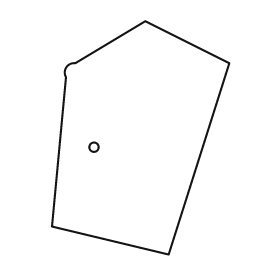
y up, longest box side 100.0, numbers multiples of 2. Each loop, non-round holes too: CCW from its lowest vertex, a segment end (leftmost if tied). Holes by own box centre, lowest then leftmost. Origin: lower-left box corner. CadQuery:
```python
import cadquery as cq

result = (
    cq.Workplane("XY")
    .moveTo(50.0, 0.0)
    .lineTo(76.0, 82.0)
    .lineTo(40.0, 100.0)
    .lineTo(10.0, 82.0)
    .threePointArc((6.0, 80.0), (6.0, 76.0))
    .lineTo(0.0, 12.0)
    .close()
    .moveTo(18.0, 46.0)
    .circle(2.0)
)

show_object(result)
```